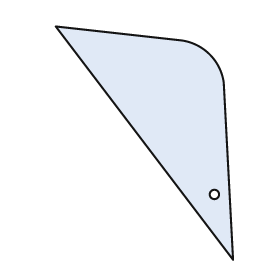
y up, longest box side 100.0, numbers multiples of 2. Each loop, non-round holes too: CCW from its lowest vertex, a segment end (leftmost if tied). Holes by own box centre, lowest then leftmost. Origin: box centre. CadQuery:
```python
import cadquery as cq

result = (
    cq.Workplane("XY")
    .moveTo(38.0, -50.0)
    .lineTo(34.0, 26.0)
    .threePointArc((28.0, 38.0), (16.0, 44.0))
    .lineTo(-38.0, 50.0)
    .close()
    .moveTo(30.0, -22.0)
    .circle(2.0)
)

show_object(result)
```